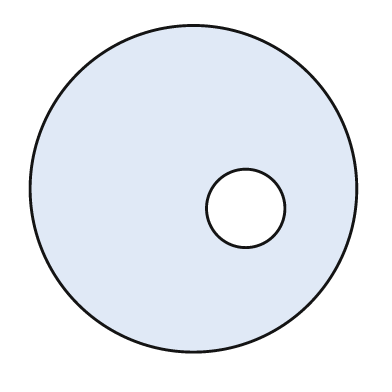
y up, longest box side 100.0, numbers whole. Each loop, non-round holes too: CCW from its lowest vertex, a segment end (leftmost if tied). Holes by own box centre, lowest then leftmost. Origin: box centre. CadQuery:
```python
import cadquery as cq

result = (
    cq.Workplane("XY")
    .moveTo(0.0, 0.0)
    .circle(50.0)
    .moveTo(16.0, -6.0)
    .circle(12.0)
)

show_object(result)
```